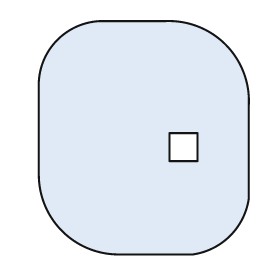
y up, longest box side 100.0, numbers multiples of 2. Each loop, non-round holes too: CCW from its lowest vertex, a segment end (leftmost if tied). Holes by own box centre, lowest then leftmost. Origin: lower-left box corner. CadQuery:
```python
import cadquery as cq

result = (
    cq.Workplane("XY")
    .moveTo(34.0, 0.0)
    .lineTo(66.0, 0.0)
    .threePointArc((82.0, 8.0), (90.0, 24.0))
    .lineTo(90.0, 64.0)
    .threePointArc((80.0, 90.0), (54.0, 100.0))
    .lineTo(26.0, 100.0)
    .threePointArc((8.0, 92.0), (0.0, 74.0))
    .lineTo(0.0, 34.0)
    .threePointArc((10.0, 10.0), (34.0, 0.0))
    .close()
    .moveTo(56.0, 40.0)
    .lineTo(68.0, 40.0)
    .lineTo(68.0, 52.0)
    .lineTo(56.0, 52.0)
    .close()
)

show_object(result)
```